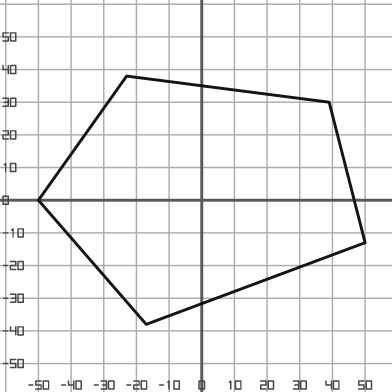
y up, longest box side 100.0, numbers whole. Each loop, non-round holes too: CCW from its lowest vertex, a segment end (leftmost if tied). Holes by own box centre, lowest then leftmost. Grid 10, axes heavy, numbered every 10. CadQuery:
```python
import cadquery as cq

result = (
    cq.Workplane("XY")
    .moveTo(-17.0, -38.0)
    .lineTo(50.0, -13.0)
    .lineTo(39.0, 30.0)
    .lineTo(-23.0, 38.0)
    .lineTo(-50.0, 0.0)
    .close()
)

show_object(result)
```